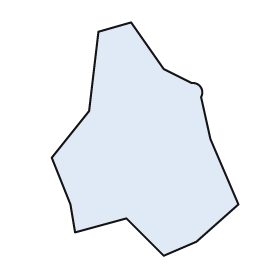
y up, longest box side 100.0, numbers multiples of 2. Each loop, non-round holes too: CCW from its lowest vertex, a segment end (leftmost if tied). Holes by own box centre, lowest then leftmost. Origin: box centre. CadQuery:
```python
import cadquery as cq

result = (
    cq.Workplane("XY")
    .moveTo(8.0, -50.0)
    .lineTo(22.0, -44.0)
    .lineTo(40.0, -28.0)
    .lineTo(28.0, 0.0)
    .lineTo(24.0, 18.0)
    .threePointArc((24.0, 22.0), (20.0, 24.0))
    .lineTo(8.0, 30.0)
    .lineTo(-6.0, 50.0)
    .lineTo(-20.0, 46.0)
    .lineTo(-24.0, 12.0)
    .lineTo(-40.0, -8.0)
    .lineTo(-32.0, -28.0)
    .lineTo(-30.0, -40.0)
    .lineTo(-8.0, -34.0)
    .close()
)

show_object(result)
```